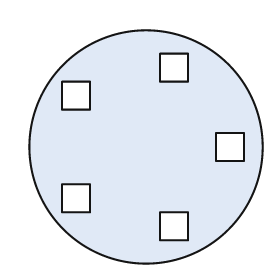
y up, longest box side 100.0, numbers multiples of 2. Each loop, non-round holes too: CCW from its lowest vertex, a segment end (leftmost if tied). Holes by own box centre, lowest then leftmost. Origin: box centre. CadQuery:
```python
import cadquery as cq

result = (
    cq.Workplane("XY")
    .moveTo(0.0, 0.0)
    .circle(50.0)
    .moveTo(6.0, -40.0)
    .lineTo(18.0, -40.0)
    .lineTo(18.0, -28.0)
    .lineTo(6.0, -28.0)
    .close()
    .moveTo(-36.0, -28.0)
    .lineTo(-24.0, -28.0)
    .lineTo(-24.0, -16.0)
    .lineTo(-36.0, -16.0)
    .close()
    .moveTo(30.0, -6.0)
    .lineTo(42.0, -6.0)
    .lineTo(42.0, 6.0)
    .lineTo(30.0, 6.0)
    .close()
    .moveTo(-36.0, 16.0)
    .lineTo(-24.0, 16.0)
    .lineTo(-24.0, 28.0)
    .lineTo(-36.0, 28.0)
    .close()
    .moveTo(6.0, 28.0)
    .lineTo(18.0, 28.0)
    .lineTo(18.0, 40.0)
    .lineTo(6.0, 40.0)
    .close()
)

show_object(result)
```